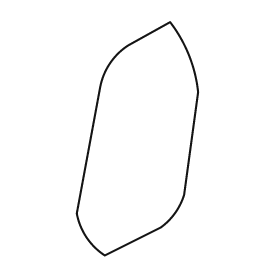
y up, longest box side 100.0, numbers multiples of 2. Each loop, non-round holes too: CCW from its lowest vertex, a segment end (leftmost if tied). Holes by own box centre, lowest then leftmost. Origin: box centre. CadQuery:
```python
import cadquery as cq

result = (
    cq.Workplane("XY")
    .moveTo(-14.0, -50.0)
    .lineTo(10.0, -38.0)
    .threePointArc((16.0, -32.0), (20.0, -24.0))
    .lineTo(26.0, 20.0)
    .threePointArc((22.0, 36.0), (14.0, 50.0))
    .lineTo(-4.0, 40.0)
    .threePointArc((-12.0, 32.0), (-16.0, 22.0))
    .lineTo(-26.0, -32.0)
    .threePointArc((-22.0, -42.0), (-14.0, -50.0))
    .close()
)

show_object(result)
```